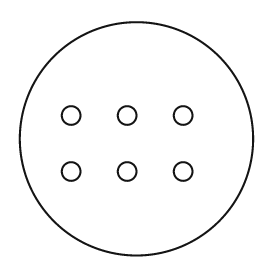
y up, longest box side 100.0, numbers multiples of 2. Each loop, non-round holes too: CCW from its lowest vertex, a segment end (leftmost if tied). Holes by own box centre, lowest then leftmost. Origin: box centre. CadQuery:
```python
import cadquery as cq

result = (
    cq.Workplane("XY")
    .moveTo(0.0, 0.0)
    .circle(50.0)
    .moveTo(-28.0, -14.0)
    .circle(4.0)
    .moveTo(-4.0, -14.0)
    .circle(4.0)
    .moveTo(20.0, -14.0)
    .circle(4.0)
    .moveTo(-28.0, 10.0)
    .circle(4.0)
    .moveTo(-4.0, 10.0)
    .circle(4.0)
    .moveTo(20.0, 10.0)
    .circle(4.0)
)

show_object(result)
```